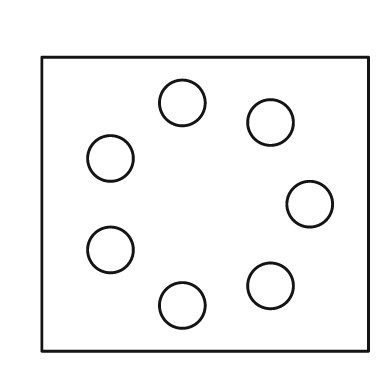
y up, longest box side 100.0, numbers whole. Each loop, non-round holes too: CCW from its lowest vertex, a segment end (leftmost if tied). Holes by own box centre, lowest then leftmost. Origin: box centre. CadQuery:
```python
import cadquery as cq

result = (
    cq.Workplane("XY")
    .moveTo(-50.0, -45.0)
    .lineTo(50.0, -45.0)
    .lineTo(50.0, 45.0)
    .lineTo(-50.0, 45.0)
    .close()
    .moveTo(-7.0, -31.0)
    .circle(7.0)
    .moveTo(20.0, -25.0)
    .circle(7.0)
    .moveTo(-29.0, -14.0)
    .circle(7.0)
    .moveTo(32.0, 0.0)
    .circle(7.0)
    .moveTo(-29.0, 14.0)
    .circle(7.0)
    .moveTo(20.0, 25.0)
    .circle(7.0)
    .moveTo(-7.0, 31.0)
    .circle(7.0)
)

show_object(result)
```